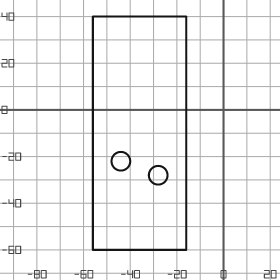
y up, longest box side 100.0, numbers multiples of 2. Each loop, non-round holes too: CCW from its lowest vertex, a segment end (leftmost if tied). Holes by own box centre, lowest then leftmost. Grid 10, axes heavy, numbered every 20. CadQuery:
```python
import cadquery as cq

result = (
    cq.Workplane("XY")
    .moveTo(-56.0, -60.0)
    .lineTo(-16.0, -60.0)
    .lineTo(-16.0, 40.0)
    .lineTo(-56.0, 40.0)
    .close()
    .moveTo(-28.0, -28.0)
    .circle(4.0)
    .moveTo(-44.0, -22.0)
    .circle(4.0)
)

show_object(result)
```